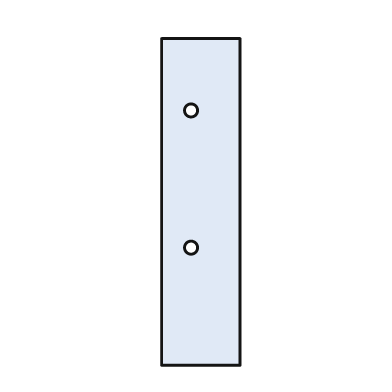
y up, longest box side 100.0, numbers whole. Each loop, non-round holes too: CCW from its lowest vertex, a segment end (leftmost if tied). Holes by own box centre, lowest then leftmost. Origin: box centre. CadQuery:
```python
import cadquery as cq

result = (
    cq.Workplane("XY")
    .moveTo(-12.0, -50.0)
    .lineTo(12.0, -50.0)
    .lineTo(12.0, 50.0)
    .lineTo(-12.0, 50.0)
    .close()
    .moveTo(-3.0, -14.0)
    .circle(2.0)
    .moveTo(-3.0, 28.0)
    .circle(2.0)
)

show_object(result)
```